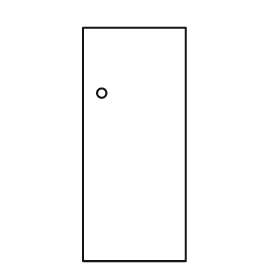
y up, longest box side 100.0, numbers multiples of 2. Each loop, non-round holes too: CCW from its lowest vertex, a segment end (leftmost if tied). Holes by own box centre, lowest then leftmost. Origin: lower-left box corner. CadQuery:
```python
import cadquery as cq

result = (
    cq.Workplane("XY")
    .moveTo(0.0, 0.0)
    .lineTo(44.0, 0.0)
    .lineTo(44.0, 100.0)
    .lineTo(0.0, 100.0)
    .close()
    .moveTo(8.0, 72.0)
    .circle(2.0)
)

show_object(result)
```